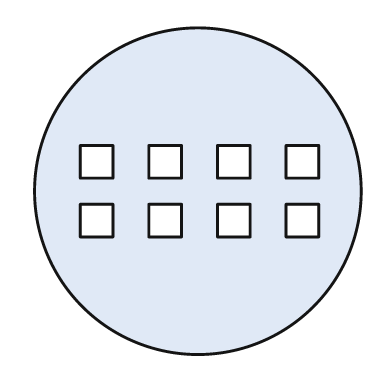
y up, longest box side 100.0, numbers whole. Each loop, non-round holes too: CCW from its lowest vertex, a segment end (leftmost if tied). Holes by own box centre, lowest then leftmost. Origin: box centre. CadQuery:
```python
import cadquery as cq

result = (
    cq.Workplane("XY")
    .moveTo(0.0, 0.0)
    .circle(50.0)
    .moveTo(-36.0, -14.0)
    .lineTo(-26.0, -14.0)
    .lineTo(-26.0, -4.0)
    .lineTo(-36.0, -4.0)
    .close()
    .moveTo(-15.0, -14.0)
    .lineTo(-5.0, -14.0)
    .lineTo(-5.0, -4.0)
    .lineTo(-15.0, -4.0)
    .close()
    .moveTo(6.0, -14.0)
    .lineTo(16.0, -14.0)
    .lineTo(16.0, -4.0)
    .lineTo(6.0, -4.0)
    .close()
    .moveTo(27.0, -14.0)
    .lineTo(37.0, -14.0)
    .lineTo(37.0, -4.0)
    .lineTo(27.0, -4.0)
    .close()
    .moveTo(-36.0, 4.0)
    .lineTo(-26.0, 4.0)
    .lineTo(-26.0, 14.0)
    .lineTo(-36.0, 14.0)
    .close()
    .moveTo(-15.0, 4.0)
    .lineTo(-5.0, 4.0)
    .lineTo(-5.0, 14.0)
    .lineTo(-15.0, 14.0)
    .close()
    .moveTo(6.0, 4.0)
    .lineTo(16.0, 4.0)
    .lineTo(16.0, 14.0)
    .lineTo(6.0, 14.0)
    .close()
    .moveTo(27.0, 4.0)
    .lineTo(37.0, 4.0)
    .lineTo(37.0, 14.0)
    .lineTo(27.0, 14.0)
    .close()
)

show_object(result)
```